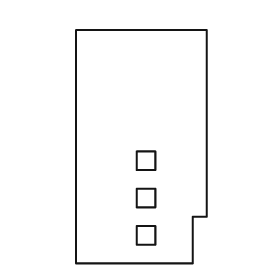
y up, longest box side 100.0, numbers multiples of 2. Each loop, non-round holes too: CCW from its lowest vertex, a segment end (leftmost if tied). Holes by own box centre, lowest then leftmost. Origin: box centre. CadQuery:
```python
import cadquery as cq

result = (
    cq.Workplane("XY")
    .moveTo(-28.0, -50.0)
    .lineTo(22.0, -50.0)
    .lineTo(22.0, -30.0)
    .lineTo(28.0, -30.0)
    .lineTo(28.0, 50.0)
    .lineTo(-28.0, 50.0)
    .close()
    .moveTo(-2.0, -42.0)
    .lineTo(6.0, -42.0)
    .lineTo(6.0, -34.0)
    .lineTo(-2.0, -34.0)
    .close()
    .moveTo(-2.0, -26.0)
    .lineTo(6.0, -26.0)
    .lineTo(6.0, -18.0)
    .lineTo(-2.0, -18.0)
    .close()
    .moveTo(-2.0, -10.0)
    .lineTo(6.0, -10.0)
    .lineTo(6.0, -2.0)
    .lineTo(-2.0, -2.0)
    .close()
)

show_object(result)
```